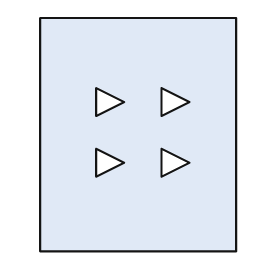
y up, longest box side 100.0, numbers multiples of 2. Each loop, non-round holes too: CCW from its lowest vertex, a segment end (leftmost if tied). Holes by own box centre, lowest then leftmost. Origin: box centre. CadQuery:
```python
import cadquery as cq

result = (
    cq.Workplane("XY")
    .moveTo(-42.0, -50.0)
    .lineTo(42.0, -50.0)
    .lineTo(42.0, 50.0)
    .lineTo(-42.0, 50.0)
    .close()
    .moveTo(-18.0, -18.0)
    .lineTo(-6.0, -12.0)
    .lineTo(-18.0, -6.0)
    .close()
    .moveTo(10.0, -18.0)
    .lineTo(22.0, -12.0)
    .lineTo(10.0, -6.0)
    .close()
    .moveTo(-18.0, 8.0)
    .lineTo(-6.0, 14.0)
    .lineTo(-18.0, 20.0)
    .close()
    .moveTo(10.0, 8.0)
    .lineTo(22.0, 14.0)
    .lineTo(10.0, 20.0)
    .close()
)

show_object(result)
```